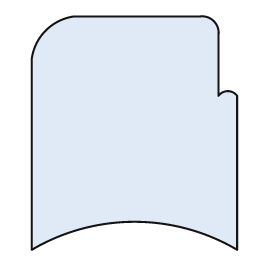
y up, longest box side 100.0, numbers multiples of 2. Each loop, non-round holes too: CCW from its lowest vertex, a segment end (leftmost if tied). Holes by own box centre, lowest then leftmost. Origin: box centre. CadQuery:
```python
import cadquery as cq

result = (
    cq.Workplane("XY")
    .moveTo(-44.0, -50.0)
    .threePointArc((0.0, -38.0), (44.0, -50.0))
    .lineTo(44.0, 16.0)
    .threePointArc((40.0, 18.0), (36.0, 16.0))
    .lineTo(36.0, 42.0)
    .threePointArc((34.0, 48.0), (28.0, 50.0))
    .lineTo(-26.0, 50.0)
    .threePointArc((-38.0, 44.0), (-44.0, 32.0))
    .close()
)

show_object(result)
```